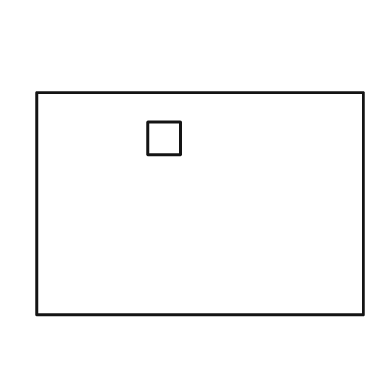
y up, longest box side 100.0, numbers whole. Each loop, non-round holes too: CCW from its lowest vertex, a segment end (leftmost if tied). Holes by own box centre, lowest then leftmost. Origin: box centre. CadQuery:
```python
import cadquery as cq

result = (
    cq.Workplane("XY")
    .moveTo(-50.0, -34.0)
    .lineTo(50.0, -34.0)
    .lineTo(50.0, 34.0)
    .lineTo(-50.0, 34.0)
    .close()
    .moveTo(-16.0, 15.0)
    .lineTo(-6.0, 15.0)
    .lineTo(-6.0, 25.0)
    .lineTo(-16.0, 25.0)
    .close()
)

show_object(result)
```